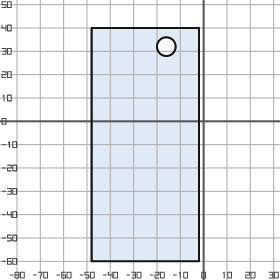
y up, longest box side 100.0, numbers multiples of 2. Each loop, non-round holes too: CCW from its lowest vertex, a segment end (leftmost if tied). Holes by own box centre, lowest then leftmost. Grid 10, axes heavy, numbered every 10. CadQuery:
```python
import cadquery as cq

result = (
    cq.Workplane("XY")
    .moveTo(-48.0, -60.0)
    .lineTo(-2.0, -60.0)
    .lineTo(-2.0, 40.0)
    .lineTo(-48.0, 40.0)
    .close()
    .moveTo(-16.0, 32.0)
    .circle(4.0)
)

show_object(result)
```